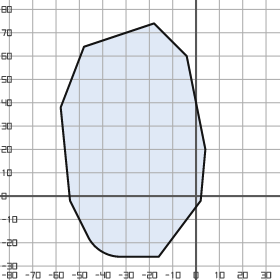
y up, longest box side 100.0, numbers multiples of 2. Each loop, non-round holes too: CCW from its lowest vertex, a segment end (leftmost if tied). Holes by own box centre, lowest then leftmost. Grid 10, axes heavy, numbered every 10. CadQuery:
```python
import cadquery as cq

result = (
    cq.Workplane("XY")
    .moveTo(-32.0, -26.0)
    .lineTo(-16.0, -26.0)
    .lineTo(2.0, -2.0)
    .lineTo(4.0, 20.0)
    .lineTo(-4.0, 60.0)
    .lineTo(-18.0, 74.0)
    .lineTo(-48.0, 64.0)
    .lineTo(-58.0, 38.0)
    .lineTo(-54.0, -2.0)
    .lineTo(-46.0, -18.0)
    .threePointArc((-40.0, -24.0), (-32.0, -26.0))
    .close()
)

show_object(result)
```